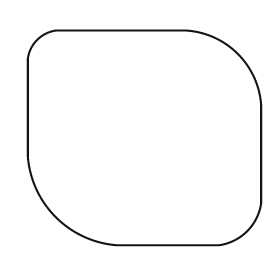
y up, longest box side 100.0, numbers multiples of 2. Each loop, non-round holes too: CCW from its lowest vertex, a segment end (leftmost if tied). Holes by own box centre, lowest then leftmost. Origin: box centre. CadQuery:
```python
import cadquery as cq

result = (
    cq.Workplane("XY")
    .moveTo(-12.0, -46.0)
    .lineTo(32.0, -46.0)
    .threePointArc((44.0, -40.0), (50.0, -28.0))
    .lineTo(50.0, 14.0)
    .threePointArc((40.0, 36.0), (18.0, 46.0))
    .lineTo(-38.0, 46.0)
    .threePointArc((-46.0, 42.0), (-50.0, 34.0))
    .lineTo(-50.0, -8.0)
    .threePointArc((-38.0, -34.0), (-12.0, -46.0))
    .close()
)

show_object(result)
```